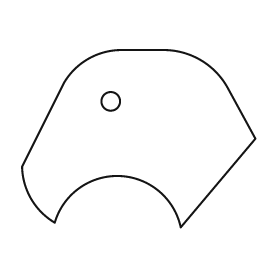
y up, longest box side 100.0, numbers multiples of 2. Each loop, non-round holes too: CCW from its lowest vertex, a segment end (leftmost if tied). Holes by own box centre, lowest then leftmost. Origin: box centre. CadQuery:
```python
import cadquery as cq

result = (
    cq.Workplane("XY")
    .moveTo(18.0, -38.0)
    .lineTo(50.0, 0.0)
    .lineTo(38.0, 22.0)
    .threePointArc((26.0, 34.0), (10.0, 38.0))
    .lineTo(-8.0, 38.0)
    .threePointArc((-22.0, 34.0), (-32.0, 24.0))
    .lineTo(-50.0, -12.0)
    .threePointArc((-46.0, -26.0), (-36.0, -36.0))
    .threePointArc((-8.0, -16.0), (18.0, -38.0))
    .close()
    .moveTo(-12.0, 16.0)
    .circle(4.0)
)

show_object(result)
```